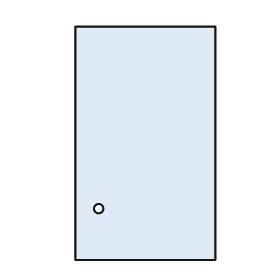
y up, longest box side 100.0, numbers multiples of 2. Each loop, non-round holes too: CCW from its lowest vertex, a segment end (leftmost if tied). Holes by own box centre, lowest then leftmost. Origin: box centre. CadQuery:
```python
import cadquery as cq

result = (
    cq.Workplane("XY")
    .moveTo(-30.0, -50.0)
    .lineTo(30.0, -50.0)
    .lineTo(30.0, 50.0)
    .lineTo(-30.0, 50.0)
    .close()
    .moveTo(-20.0, -28.0)
    .circle(2.0)
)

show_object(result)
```